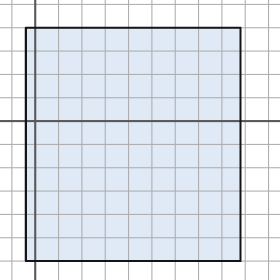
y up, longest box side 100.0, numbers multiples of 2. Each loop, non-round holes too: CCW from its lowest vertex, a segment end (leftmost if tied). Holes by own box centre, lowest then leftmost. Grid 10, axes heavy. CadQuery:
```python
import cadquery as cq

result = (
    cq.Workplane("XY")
    .moveTo(-4.0, -60.0)
    .lineTo(88.0, -60.0)
    .lineTo(88.0, 40.0)
    .lineTo(-4.0, 40.0)
    .close()
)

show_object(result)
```